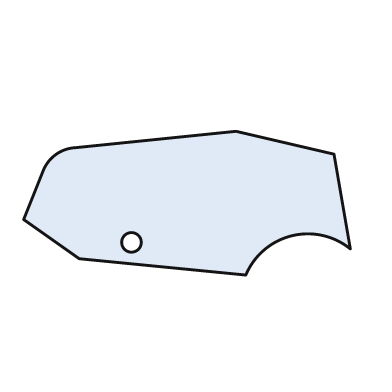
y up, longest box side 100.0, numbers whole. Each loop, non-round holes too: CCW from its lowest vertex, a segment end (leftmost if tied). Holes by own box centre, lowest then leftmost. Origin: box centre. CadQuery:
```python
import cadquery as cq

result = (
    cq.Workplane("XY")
    .moveTo(18.0, -22.0)
    .threePointArc((32.0, -10.0), (50.0, -14.0))
    .lineTo(45.0, 15.0)
    .lineTo(15.0, 22.0)
    .lineTo(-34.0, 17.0)
    .threePointArc((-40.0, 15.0), (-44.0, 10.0))
    .lineTo(-50.0, -5.0)
    .lineTo(-33.0, -17.0)
    .close()
    .moveTo(-17.0, -12.0)
    .circle(3.0)
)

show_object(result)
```